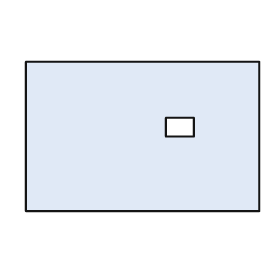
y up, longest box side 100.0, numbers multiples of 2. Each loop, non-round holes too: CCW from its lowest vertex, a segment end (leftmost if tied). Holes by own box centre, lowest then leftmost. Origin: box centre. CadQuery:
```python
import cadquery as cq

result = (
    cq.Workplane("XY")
    .moveTo(-50.0, -32.0)
    .lineTo(50.0, -32.0)
    .lineTo(50.0, 32.0)
    .lineTo(-50.0, 32.0)
    .close()
    .moveTo(10.0, 0.0)
    .lineTo(22.0, 0.0)
    .lineTo(22.0, 8.0)
    .lineTo(10.0, 8.0)
    .close()
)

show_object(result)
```